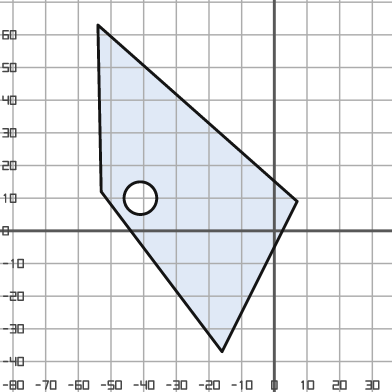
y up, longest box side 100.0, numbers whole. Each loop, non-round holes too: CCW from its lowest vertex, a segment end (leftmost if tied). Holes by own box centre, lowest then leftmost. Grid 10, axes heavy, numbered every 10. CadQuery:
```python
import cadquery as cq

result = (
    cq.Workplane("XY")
    .moveTo(-16.0, -37.0)
    .lineTo(7.0, 9.0)
    .lineTo(-54.0, 63.0)
    .lineTo(-53.0, 12.0)
    .close()
    .moveTo(-41.0, 10.0)
    .circle(5.0)
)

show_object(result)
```